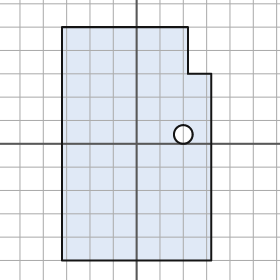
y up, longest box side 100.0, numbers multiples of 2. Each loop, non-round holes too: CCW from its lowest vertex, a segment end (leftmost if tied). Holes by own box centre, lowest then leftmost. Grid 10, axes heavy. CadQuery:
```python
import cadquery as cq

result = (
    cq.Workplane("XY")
    .moveTo(-32.0, -50.0)
    .lineTo(32.0, -50.0)
    .lineTo(32.0, 30.0)
    .lineTo(22.0, 30.0)
    .lineTo(22.0, 50.0)
    .lineTo(-32.0, 50.0)
    .close()
    .moveTo(20.0, 4.0)
    .circle(4.0)
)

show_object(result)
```